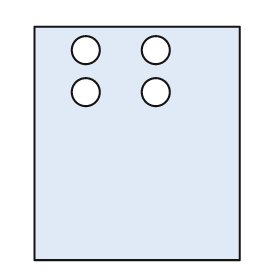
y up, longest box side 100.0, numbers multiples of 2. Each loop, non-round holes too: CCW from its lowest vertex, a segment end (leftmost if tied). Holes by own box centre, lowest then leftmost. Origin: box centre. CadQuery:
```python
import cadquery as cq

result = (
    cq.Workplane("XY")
    .moveTo(-44.0, -50.0)
    .lineTo(44.0, -50.0)
    .lineTo(44.0, 50.0)
    .lineTo(-44.0, 50.0)
    .close()
    .moveTo(-22.0, 22.0)
    .circle(6.0)
    .moveTo(8.0, 22.0)
    .circle(6.0)
    .moveTo(-22.0, 40.0)
    .circle(6.0)
    .moveTo(8.0, 40.0)
    .circle(6.0)
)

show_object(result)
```